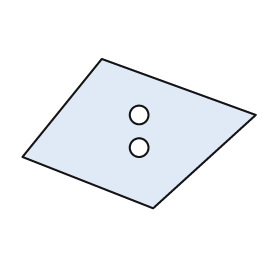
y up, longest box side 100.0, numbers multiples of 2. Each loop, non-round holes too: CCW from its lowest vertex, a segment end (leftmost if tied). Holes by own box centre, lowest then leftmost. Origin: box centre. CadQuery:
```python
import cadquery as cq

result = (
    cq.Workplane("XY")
    .moveTo(6.0, -32.0)
    .lineTo(50.0, 8.0)
    .lineTo(-16.0, 32.0)
    .lineTo(-50.0, -10.0)
    .close()
    .moveTo(0.0, -6.0)
    .circle(4.0)
    .moveTo(0.0, 8.0)
    .circle(4.0)
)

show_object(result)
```